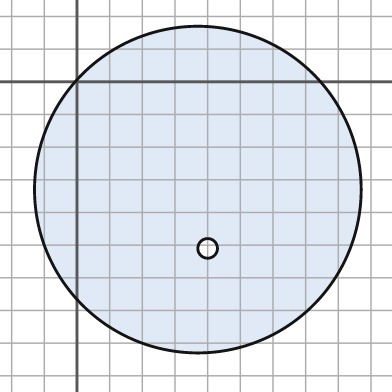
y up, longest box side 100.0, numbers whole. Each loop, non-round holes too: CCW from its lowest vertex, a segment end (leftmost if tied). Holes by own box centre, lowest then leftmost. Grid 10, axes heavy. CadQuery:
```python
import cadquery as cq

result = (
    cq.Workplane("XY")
    .moveTo(37.0, -33.0)
    .circle(50.0)
    .moveTo(40.0, -51.0)
    .circle(3.0)
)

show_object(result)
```